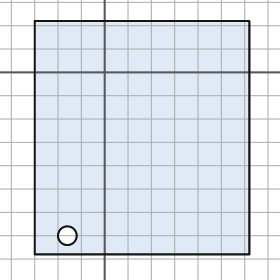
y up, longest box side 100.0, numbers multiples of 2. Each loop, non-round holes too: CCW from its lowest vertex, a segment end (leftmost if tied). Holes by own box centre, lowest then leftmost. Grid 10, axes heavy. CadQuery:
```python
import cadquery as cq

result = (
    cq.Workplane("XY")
    .moveTo(-30.0, -78.0)
    .lineTo(62.0, -78.0)
    .lineTo(62.0, 22.0)
    .lineTo(-30.0, 22.0)
    .close()
    .moveTo(-16.0, -70.0)
    .circle(4.0)
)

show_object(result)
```